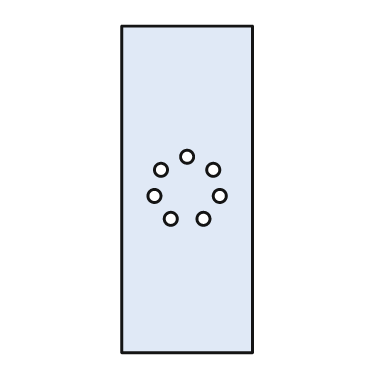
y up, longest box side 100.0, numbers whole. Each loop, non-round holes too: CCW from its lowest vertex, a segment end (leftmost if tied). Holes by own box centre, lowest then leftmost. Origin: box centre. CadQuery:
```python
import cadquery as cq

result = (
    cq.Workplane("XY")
    .moveTo(-20.0, -50.0)
    .lineTo(20.0, -50.0)
    .lineTo(20.0, 50.0)
    .lineTo(-20.0, 50.0)
    .close()
    .moveTo(-5.0, -9.0)
    .circle(2.0)
    .moveTo(5.0, -9.0)
    .circle(2.0)
    .moveTo(-10.0, -2.0)
    .circle(2.0)
    .moveTo(10.0, -2.0)
    .circle(2.0)
    .moveTo(-8.0, 6.0)
    .circle(2.0)
    .moveTo(8.0, 6.0)
    .circle(2.0)
    .moveTo(0.0, 10.0)
    .circle(2.0)
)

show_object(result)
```